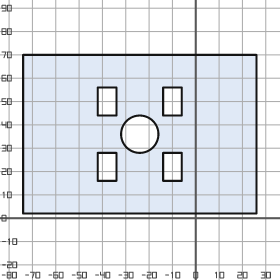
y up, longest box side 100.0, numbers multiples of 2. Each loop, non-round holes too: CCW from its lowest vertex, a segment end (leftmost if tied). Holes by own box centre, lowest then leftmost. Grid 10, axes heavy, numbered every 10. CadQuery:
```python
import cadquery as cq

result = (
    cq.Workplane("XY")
    .moveTo(-74.0, 2.0)
    .lineTo(26.0, 2.0)
    .lineTo(26.0, 70.0)
    .lineTo(-74.0, 70.0)
    .close()
    .moveTo(-42.0, 16.0)
    .lineTo(-34.0, 16.0)
    .lineTo(-34.0, 28.0)
    .lineTo(-42.0, 28.0)
    .close()
    .moveTo(-14.0, 16.0)
    .lineTo(-6.0, 16.0)
    .lineTo(-6.0, 28.0)
    .lineTo(-14.0, 28.0)
    .close()
    .moveTo(-24.0, 36.0)
    .circle(8.0)
    .moveTo(-42.0, 44.0)
    .lineTo(-34.0, 44.0)
    .lineTo(-34.0, 56.0)
    .lineTo(-42.0, 56.0)
    .close()
    .moveTo(-14.0, 44.0)
    .lineTo(-6.0, 44.0)
    .lineTo(-6.0, 56.0)
    .lineTo(-14.0, 56.0)
    .close()
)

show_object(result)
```